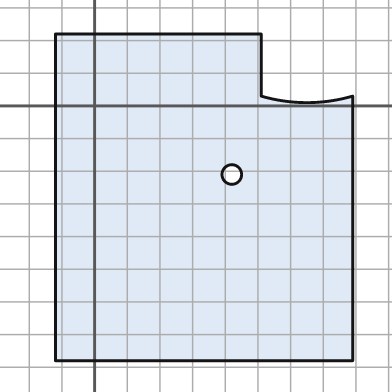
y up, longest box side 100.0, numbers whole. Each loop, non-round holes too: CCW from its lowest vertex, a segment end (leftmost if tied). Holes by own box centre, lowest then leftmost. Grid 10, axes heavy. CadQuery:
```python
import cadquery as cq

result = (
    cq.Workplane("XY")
    .moveTo(-12.0, -78.0)
    .lineTo(79.0, -78.0)
    .lineTo(79.0, 3.0)
    .threePointArc((65.0, 1.0), (51.0, 3.0))
    .lineTo(51.0, 22.0)
    .lineTo(-12.0, 22.0)
    .close()
    .moveTo(42.0, -21.0)
    .circle(3.0)
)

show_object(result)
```